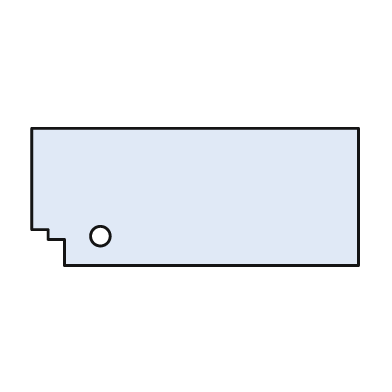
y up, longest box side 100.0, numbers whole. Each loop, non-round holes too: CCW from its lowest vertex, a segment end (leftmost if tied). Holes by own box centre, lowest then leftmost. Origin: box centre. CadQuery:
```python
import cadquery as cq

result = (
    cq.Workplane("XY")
    .moveTo(-40.0, -21.0)
    .lineTo(50.0, -21.0)
    .lineTo(50.0, 21.0)
    .lineTo(-50.0, 21.0)
    .lineTo(-50.0, -10.0)
    .lineTo(-45.0, -10.0)
    .lineTo(-45.0, -13.0)
    .lineTo(-40.0, -13.0)
    .close()
    .moveTo(-29.0, -12.0)
    .circle(3.0)
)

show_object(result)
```